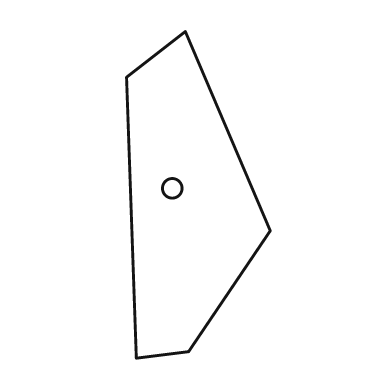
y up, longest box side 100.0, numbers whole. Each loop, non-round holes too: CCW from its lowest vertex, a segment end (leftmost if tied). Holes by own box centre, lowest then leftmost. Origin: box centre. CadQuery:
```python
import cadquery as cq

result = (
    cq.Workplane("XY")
    .moveTo(-19.0, -50.0)
    .lineTo(-3.0, -48.0)
    .lineTo(22.0, -11.0)
    .lineTo(-4.0, 50.0)
    .lineTo(-22.0, 36.0)
    .close()
    .moveTo(-8.0, 2.0)
    .circle(3.0)
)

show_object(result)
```